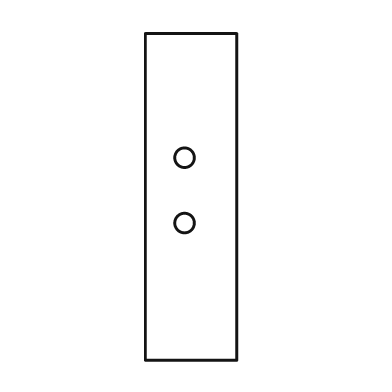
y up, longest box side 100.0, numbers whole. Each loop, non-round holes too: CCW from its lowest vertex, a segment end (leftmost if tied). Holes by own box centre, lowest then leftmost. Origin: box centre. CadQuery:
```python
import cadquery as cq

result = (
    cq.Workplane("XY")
    .moveTo(-14.0, -50.0)
    .lineTo(14.0, -50.0)
    .lineTo(14.0, 50.0)
    .lineTo(-14.0, 50.0)
    .close()
    .moveTo(-2.0, -8.0)
    .circle(3.0)
    .moveTo(-2.0, 12.0)
    .circle(3.0)
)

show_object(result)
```